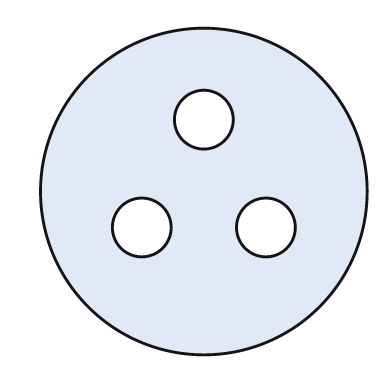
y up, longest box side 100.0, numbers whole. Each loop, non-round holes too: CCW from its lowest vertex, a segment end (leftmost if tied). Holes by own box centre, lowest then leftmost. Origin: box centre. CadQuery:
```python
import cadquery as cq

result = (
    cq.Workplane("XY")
    .moveTo(0.0, 0.0)
    .circle(50.0)
    .moveTo(-19.0, -11.0)
    .circle(9.0)
    .moveTo(19.0, -11.0)
    .circle(9.0)
    .moveTo(0.0, 22.0)
    .circle(9.0)
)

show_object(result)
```